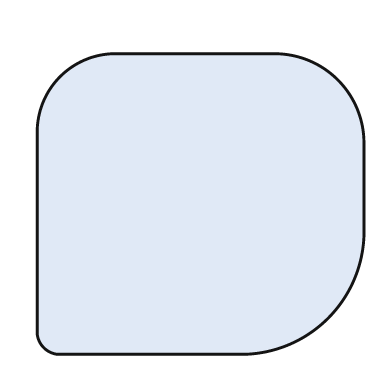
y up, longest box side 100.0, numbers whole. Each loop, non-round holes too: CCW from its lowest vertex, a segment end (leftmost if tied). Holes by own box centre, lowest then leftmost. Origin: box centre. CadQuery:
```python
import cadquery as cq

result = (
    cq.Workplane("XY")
    .moveTo(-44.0, -46.0)
    .lineTo(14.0, -46.0)
    .threePointArc((39.0, -35.0), (50.0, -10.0))
    .lineTo(50.0, 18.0)
    .threePointArc((42.0, 38.0), (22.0, 46.0))
    .lineTo(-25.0, 46.0)
    .threePointArc((-43.0, 39.0), (-50.0, 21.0))
    .lineTo(-50.0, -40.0)
    .threePointArc((-48.0, -44.0), (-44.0, -46.0))
    .close()
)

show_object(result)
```